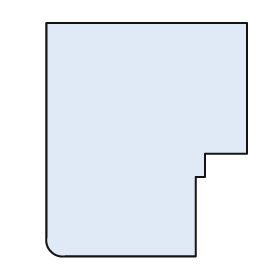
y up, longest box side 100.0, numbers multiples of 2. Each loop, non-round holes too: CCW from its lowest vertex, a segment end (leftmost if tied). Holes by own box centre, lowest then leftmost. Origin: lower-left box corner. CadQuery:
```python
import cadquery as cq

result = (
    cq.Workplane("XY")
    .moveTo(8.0, 0.0)
    .lineTo(64.0, 0.0)
    .lineTo(64.0, 34.0)
    .lineTo(68.0, 34.0)
    .lineTo(68.0, 44.0)
    .lineTo(86.0, 44.0)
    .lineTo(86.0, 100.0)
    .lineTo(0.0, 100.0)
    .lineTo(0.0, 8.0)
    .threePointArc((2.0, 2.0), (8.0, 0.0))
    .close()
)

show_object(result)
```